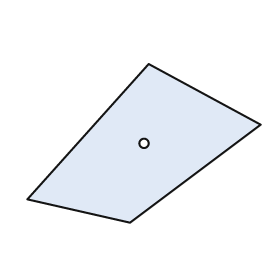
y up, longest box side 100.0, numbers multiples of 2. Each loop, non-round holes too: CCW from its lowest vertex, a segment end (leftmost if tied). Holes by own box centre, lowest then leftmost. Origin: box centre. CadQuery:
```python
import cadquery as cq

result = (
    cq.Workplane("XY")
    .moveTo(-6.0, -34.0)
    .lineTo(50.0, 8.0)
    .lineTo(2.0, 34.0)
    .lineTo(-50.0, -24.0)
    .close()
    .moveTo(0.0, 0.0)
    .circle(2.0)
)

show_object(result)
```